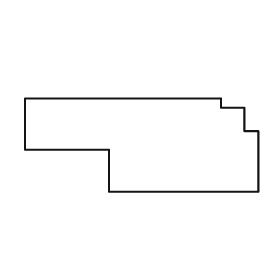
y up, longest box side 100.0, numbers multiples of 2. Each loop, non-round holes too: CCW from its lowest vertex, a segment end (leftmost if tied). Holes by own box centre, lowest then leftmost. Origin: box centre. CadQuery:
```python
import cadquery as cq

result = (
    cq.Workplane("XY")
    .moveTo(-14.0, -20.0)
    .lineTo(50.0, -20.0)
    .lineTo(50.0, 6.0)
    .lineTo(44.0, 6.0)
    .lineTo(44.0, 16.0)
    .lineTo(34.0, 16.0)
    .lineTo(34.0, 20.0)
    .lineTo(-50.0, 20.0)
    .lineTo(-50.0, -2.0)
    .lineTo(-14.0, -2.0)
    .close()
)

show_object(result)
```